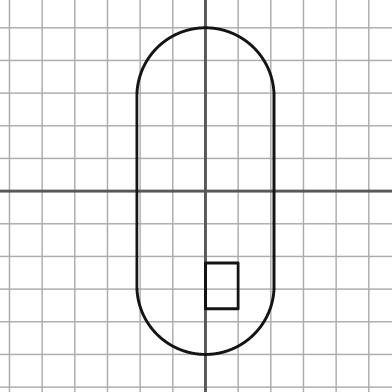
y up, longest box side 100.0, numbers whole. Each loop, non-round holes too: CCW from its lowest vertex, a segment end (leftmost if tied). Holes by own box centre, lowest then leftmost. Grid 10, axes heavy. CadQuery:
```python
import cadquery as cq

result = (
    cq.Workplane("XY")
    .moveTo(-21.0, -29.0)
    .threePointArc((0.0, -50.0), (21.0, -29.0))
    .lineTo(21.0, 29.0)
    .threePointArc((0.0, 50.0), (-21.0, 29.0))
    .close()
    .moveTo(0.0, -36.0)
    .lineTo(10.0, -36.0)
    .lineTo(10.0, -22.0)
    .lineTo(0.0, -22.0)
    .close()
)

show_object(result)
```